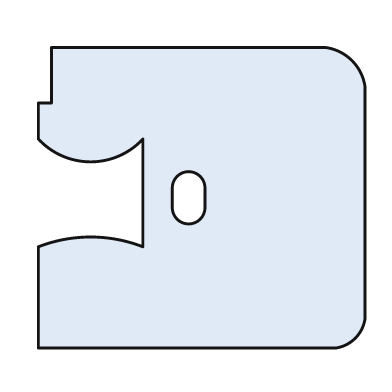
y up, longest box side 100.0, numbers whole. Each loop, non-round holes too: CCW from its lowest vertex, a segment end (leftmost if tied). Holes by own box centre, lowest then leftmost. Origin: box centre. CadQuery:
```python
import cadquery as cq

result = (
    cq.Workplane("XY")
    .moveTo(-50.0, -46.0)
    .lineTo(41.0, -46.0)
    .threePointArc((47.0, -43.0), (50.0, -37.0))
    .lineTo(50.0, 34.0)
    .threePointArc((46.0, 42.0), (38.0, 46.0))
    .lineTo(-46.0, 46.0)
    .lineTo(-46.0, 29.0)
    .lineTo(-50.0, 29.0)
    .lineTo(-50.0, 18.0)
    .threePointArc((-34.0, 11.0), (-18.0, 18.0))
    .lineTo(-18.0, -15.0)
    .threePointArc((-34.0, -12.0), (-50.0, -15.0))
    .close()
    .moveTo(-9.0, -3.0)
    .threePointArc((-4.0, -8.0), (1.0, -3.0))
    .lineTo(1.0, 3.0)
    .threePointArc((-4.0, 8.0), (-9.0, 3.0))
    .close()
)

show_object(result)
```